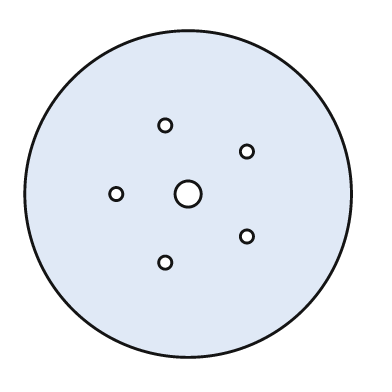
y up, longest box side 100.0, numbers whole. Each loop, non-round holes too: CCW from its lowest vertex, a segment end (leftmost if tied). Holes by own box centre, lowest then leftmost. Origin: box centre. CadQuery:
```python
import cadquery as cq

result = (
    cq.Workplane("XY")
    .moveTo(0.0, 0.0)
    .circle(50.0)
    .moveTo(-7.0, -21.0)
    .circle(2.0)
    .moveTo(18.0, -13.0)
    .circle(2.0)
    .moveTo(-22.0, 0.0)
    .circle(2.0)
    .moveTo(0.0, 0.0)
    .circle(4.0)
    .moveTo(18.0, 13.0)
    .circle(2.0)
    .moveTo(-7.0, 21.0)
    .circle(2.0)
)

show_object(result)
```